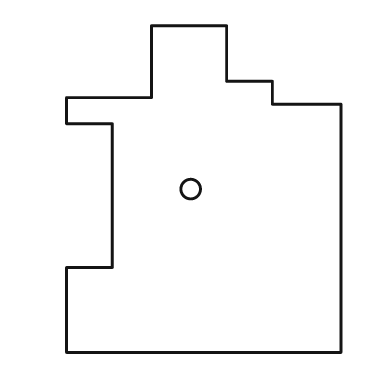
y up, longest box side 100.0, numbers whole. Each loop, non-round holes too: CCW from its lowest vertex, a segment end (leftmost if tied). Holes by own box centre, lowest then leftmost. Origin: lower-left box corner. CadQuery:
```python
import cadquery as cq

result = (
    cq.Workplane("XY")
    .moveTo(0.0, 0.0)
    .lineTo(84.0, 0.0)
    .lineTo(84.0, 76.0)
    .lineTo(63.0, 76.0)
    .lineTo(63.0, 83.0)
    .lineTo(49.0, 83.0)
    .lineTo(49.0, 100.0)
    .lineTo(26.0, 100.0)
    .lineTo(26.0, 78.0)
    .lineTo(0.0, 78.0)
    .lineTo(0.0, 70.0)
    .lineTo(14.0, 70.0)
    .lineTo(14.0, 26.0)
    .lineTo(0.0, 26.0)
    .close()
    .moveTo(38.0, 50.0)
    .circle(3.0)
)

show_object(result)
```